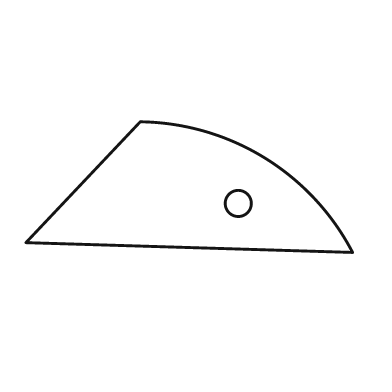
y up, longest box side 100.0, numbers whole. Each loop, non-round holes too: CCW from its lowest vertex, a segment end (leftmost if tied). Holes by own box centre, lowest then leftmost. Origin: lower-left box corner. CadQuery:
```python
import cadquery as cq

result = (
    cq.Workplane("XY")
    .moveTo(100.0, 0.0)
    .threePointArc((73.0, 29.0), (35.0, 40.0))
    .lineTo(0.0, 3.0)
    .close()
    .moveTo(65.0, 15.0)
    .circle(4.0)
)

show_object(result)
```